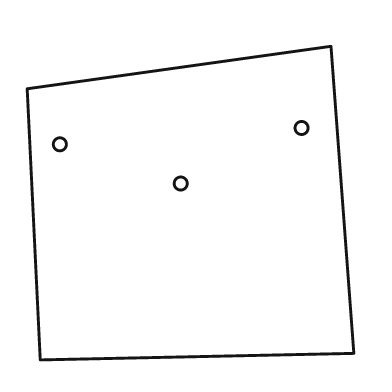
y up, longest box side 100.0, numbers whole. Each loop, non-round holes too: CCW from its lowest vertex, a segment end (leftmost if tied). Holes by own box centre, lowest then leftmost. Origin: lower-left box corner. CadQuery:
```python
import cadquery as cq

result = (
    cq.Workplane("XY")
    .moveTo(4.0, 0.0)
    .lineTo(100.0, 2.0)
    .lineTo(93.0, 96.0)
    .lineTo(0.0, 83.0)
    .close()
    .moveTo(47.0, 54.0)
    .circle(2.0)
    .moveTo(10.0, 66.0)
    .circle(2.0)
    .moveTo(84.0, 71.0)
    .circle(2.0)
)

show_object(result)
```